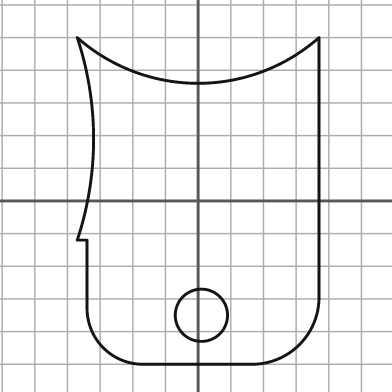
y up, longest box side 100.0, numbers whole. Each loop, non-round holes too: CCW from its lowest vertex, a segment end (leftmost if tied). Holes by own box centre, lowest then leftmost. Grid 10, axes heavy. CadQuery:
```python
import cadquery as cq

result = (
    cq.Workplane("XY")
    .moveTo(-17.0, -50.0)
    .lineTo(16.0, -50.0)
    .threePointArc((31.0, -44.0), (37.0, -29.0))
    .lineTo(37.0, 50.0)
    .threePointArc((0.0, 36.0), (-37.0, 50.0))
    .threePointArc((-32.0, 19.0), (-37.0, -12.0))
    .lineTo(-34.0, -12.0)
    .lineTo(-34.0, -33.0)
    .threePointArc((-29.0, -45.0), (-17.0, -50.0))
    .close()
    .moveTo(1.0, -35.0)
    .circle(8.0)
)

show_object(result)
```